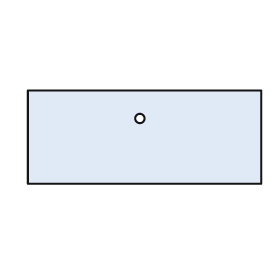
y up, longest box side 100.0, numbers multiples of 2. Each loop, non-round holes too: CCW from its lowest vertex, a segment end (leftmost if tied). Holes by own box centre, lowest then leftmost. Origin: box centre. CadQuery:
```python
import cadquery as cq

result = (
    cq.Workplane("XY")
    .moveTo(-50.0, -20.0)
    .lineTo(50.0, -20.0)
    .lineTo(50.0, 20.0)
    .lineTo(-50.0, 20.0)
    .close()
    .moveTo(-2.0, 8.0)
    .circle(2.0)
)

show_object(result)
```